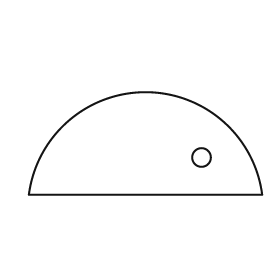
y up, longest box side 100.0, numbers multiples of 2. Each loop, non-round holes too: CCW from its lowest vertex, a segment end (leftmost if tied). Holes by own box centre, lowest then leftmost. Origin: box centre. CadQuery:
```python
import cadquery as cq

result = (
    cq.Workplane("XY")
    .moveTo(-50.0, -22.0)
    .lineTo(50.0, -22.0)
    .threePointArc((0.0, 22.0), (-50.0, -22.0))
    .close()
    .moveTo(24.0, -6.0)
    .circle(4.0)
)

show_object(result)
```